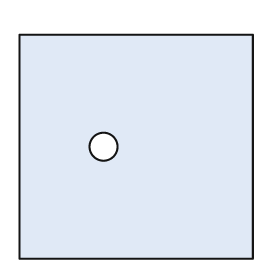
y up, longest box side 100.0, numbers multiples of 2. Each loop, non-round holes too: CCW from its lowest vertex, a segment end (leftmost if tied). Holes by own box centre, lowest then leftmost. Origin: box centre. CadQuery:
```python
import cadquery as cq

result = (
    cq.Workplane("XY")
    .moveTo(-50.0, -48.0)
    .lineTo(50.0, -48.0)
    .lineTo(50.0, 48.0)
    .lineTo(-50.0, 48.0)
    .close()
    .moveTo(-14.0, 0.0)
    .circle(6.0)
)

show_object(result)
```